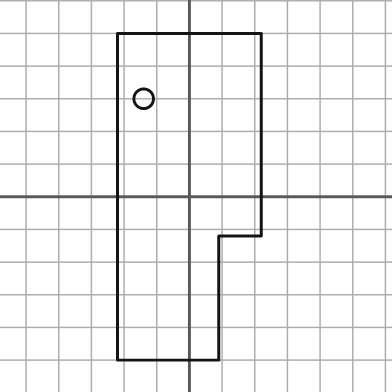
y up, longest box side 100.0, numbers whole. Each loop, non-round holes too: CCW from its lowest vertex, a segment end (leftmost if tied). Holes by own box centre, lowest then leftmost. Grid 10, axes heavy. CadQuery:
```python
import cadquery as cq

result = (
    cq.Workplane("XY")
    .moveTo(-22.0, -50.0)
    .lineTo(9.0, -50.0)
    .lineTo(9.0, -12.0)
    .lineTo(22.0, -12.0)
    .lineTo(22.0, 50.0)
    .lineTo(-22.0, 50.0)
    .close()
    .moveTo(-14.0, 30.0)
    .circle(3.0)
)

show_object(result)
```